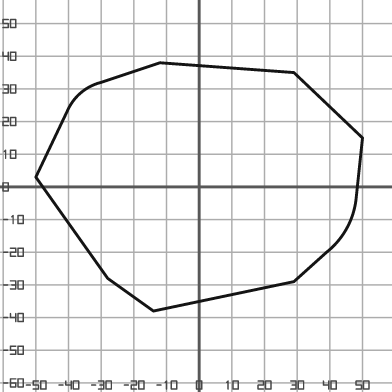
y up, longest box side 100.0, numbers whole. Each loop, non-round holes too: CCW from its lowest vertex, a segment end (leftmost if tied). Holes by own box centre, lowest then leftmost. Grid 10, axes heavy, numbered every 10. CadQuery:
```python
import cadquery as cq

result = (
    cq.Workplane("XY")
    .moveTo(-14.0, -38.0)
    .lineTo(29.0, -29.0)
    .lineTo(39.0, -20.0)
    .threePointArc((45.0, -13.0), (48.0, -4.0))
    .lineTo(50.0, 15.0)
    .lineTo(29.0, 35.0)
    .lineTo(-12.0, 38.0)
    .lineTo(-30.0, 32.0)
    .threePointArc((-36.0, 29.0), (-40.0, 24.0))
    .lineTo(-50.0, 3.0)
    .lineTo(-28.0, -28.0)
    .close()
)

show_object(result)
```